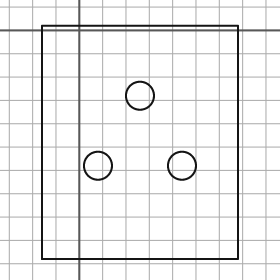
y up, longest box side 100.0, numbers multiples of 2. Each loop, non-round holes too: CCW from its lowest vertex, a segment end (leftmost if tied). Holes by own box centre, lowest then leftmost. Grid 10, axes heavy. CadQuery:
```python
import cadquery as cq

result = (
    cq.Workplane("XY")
    .moveTo(-16.0, -98.0)
    .lineTo(68.0, -98.0)
    .lineTo(68.0, 2.0)
    .lineTo(-16.0, 2.0)
    .close()
    .moveTo(8.0, -58.0)
    .circle(6.0)
    .moveTo(44.0, -58.0)
    .circle(6.0)
    .moveTo(26.0, -28.0)
    .circle(6.0)
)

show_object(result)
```